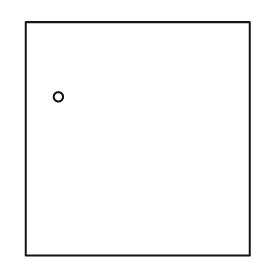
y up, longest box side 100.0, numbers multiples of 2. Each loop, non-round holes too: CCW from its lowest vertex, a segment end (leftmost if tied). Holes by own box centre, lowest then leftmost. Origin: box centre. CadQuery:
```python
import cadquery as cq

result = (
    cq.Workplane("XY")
    .moveTo(-48.0, -50.0)
    .lineTo(48.0, -50.0)
    .lineTo(48.0, 50.0)
    .lineTo(-48.0, 50.0)
    .close()
    .moveTo(-34.0, 18.0)
    .circle(2.0)
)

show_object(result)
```